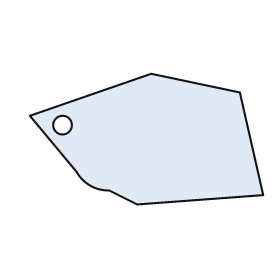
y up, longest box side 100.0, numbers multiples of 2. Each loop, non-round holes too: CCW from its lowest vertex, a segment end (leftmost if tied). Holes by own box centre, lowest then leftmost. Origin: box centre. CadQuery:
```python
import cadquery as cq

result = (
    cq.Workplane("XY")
    .moveTo(-4.0, -28.0)
    .lineTo(50.0, -24.0)
    .lineTo(40.0, 20.0)
    .lineTo(2.0, 28.0)
    .lineTo(-50.0, 10.0)
    .lineTo(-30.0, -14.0)
    .threePointArc((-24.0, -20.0), (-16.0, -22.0))
    .close()
    .moveTo(-36.0, 6.0)
    .circle(4.0)
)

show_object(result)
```